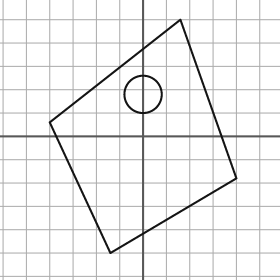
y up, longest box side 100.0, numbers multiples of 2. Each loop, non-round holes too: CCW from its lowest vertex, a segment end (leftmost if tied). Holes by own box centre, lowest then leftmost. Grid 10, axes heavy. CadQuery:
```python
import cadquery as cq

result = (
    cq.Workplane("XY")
    .moveTo(-14.0, -50.0)
    .lineTo(40.0, -18.0)
    .lineTo(16.0, 50.0)
    .lineTo(-40.0, 6.0)
    .close()
    .moveTo(0.0, 18.0)
    .circle(8.0)
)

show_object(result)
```